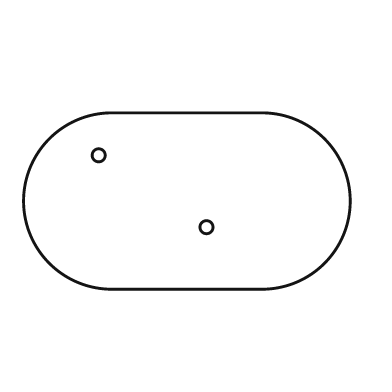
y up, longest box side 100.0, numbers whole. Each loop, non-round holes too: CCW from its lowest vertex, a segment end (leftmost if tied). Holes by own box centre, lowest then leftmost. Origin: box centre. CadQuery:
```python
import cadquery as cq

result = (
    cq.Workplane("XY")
    .moveTo(-23.0, -27.0)
    .lineTo(23.0, -27.0)
    .threePointArc((50.0, 0.0), (23.0, 27.0))
    .lineTo(-23.0, 27.0)
    .threePointArc((-50.0, 0.0), (-23.0, -27.0))
    .close()
    .moveTo(6.0, -8.0)
    .circle(2.0)
    .moveTo(-27.0, 14.0)
    .circle(2.0)
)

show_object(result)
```